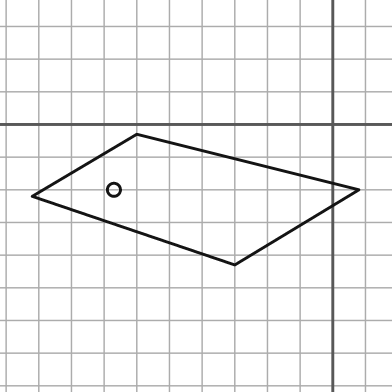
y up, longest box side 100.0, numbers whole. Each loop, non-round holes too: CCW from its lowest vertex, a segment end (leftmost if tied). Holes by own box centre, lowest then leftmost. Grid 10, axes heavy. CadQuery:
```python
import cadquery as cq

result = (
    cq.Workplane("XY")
    .moveTo(-30.0, -43.0)
    .lineTo(8.0, -20.0)
    .lineTo(-60.0, -3.0)
    .lineTo(-92.0, -22.0)
    .close()
    .moveTo(-67.0, -20.0)
    .circle(2.0)
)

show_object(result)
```